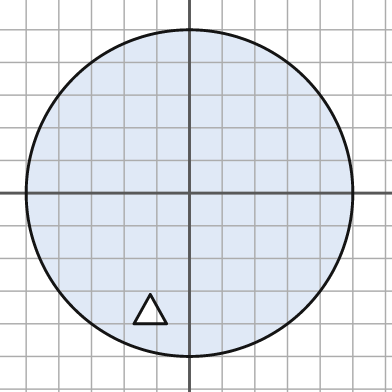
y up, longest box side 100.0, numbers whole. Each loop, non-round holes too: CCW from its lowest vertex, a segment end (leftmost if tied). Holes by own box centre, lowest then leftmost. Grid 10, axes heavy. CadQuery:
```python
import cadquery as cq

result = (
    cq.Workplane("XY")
    .moveTo(0.0, 0.0)
    .circle(50.0)
    .moveTo(-17.0, -40.0)
    .lineTo(-7.0, -40.0)
    .lineTo(-12.0, -31.0)
    .close()
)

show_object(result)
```